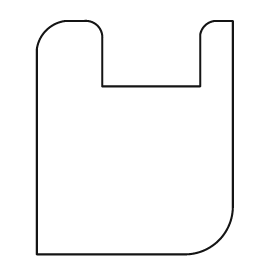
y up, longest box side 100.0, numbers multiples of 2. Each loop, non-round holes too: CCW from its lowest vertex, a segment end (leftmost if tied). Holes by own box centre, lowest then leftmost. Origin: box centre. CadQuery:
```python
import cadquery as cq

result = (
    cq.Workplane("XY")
    .moveTo(-42.0, -50.0)
    .lineTo(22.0, -50.0)
    .threePointArc((36.0, -44.0), (42.0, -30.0))
    .lineTo(42.0, 50.0)
    .lineTo(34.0, 50.0)
    .threePointArc((30.0, 48.0), (28.0, 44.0))
    .lineTo(28.0, 22.0)
    .lineTo(-14.0, 22.0)
    .lineTo(-14.0, 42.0)
    .threePointArc((-16.0, 48.0), (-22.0, 50.0))
    .lineTo(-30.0, 50.0)
    .threePointArc((-38.0, 46.0), (-42.0, 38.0))
    .close()
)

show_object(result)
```